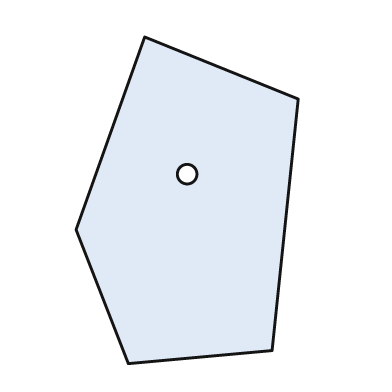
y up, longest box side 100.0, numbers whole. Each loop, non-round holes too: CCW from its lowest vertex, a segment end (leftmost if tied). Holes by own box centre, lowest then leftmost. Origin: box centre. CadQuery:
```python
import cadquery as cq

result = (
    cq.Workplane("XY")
    .moveTo(-18.0, -50.0)
    .lineTo(26.0, -46.0)
    .lineTo(34.0, 31.0)
    .lineTo(-13.0, 50.0)
    .lineTo(-34.0, -9.0)
    .close()
    .moveTo(0.0, 8.0)
    .circle(3.0)
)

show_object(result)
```